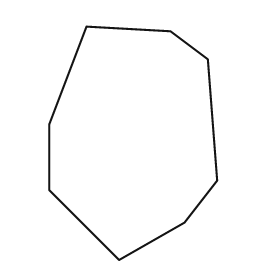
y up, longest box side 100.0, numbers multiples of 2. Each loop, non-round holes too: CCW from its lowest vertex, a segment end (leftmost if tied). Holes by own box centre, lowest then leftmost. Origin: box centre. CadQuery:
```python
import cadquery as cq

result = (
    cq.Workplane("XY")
    .moveTo(-6.0, -50.0)
    .lineTo(22.0, -34.0)
    .lineTo(36.0, -16.0)
    .lineTo(32.0, 36.0)
    .lineTo(16.0, 48.0)
    .lineTo(-20.0, 50.0)
    .lineTo(-36.0, 8.0)
    .lineTo(-36.0, -20.0)
    .close()
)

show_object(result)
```